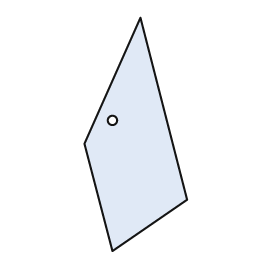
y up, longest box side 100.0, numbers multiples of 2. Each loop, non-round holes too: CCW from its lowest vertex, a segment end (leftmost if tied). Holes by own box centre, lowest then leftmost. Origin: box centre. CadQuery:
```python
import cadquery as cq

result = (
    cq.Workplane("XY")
    .moveTo(-10.0, -50.0)
    .lineTo(22.0, -28.0)
    .lineTo(2.0, 50.0)
    .lineTo(-22.0, -4.0)
    .close()
    .moveTo(-10.0, 6.0)
    .circle(2.0)
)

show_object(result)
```